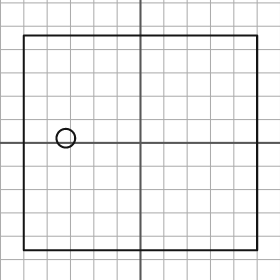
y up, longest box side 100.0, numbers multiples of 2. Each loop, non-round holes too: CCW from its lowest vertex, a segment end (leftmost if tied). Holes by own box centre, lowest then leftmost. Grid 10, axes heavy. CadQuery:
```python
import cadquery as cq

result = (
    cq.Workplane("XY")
    .moveTo(-50.0, -46.0)
    .lineTo(50.0, -46.0)
    .lineTo(50.0, 46.0)
    .lineTo(-50.0, 46.0)
    .close()
    .moveTo(-32.0, 2.0)
    .circle(4.0)
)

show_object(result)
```